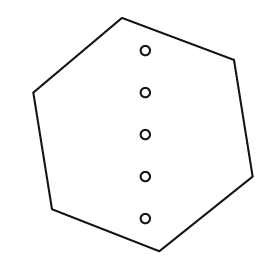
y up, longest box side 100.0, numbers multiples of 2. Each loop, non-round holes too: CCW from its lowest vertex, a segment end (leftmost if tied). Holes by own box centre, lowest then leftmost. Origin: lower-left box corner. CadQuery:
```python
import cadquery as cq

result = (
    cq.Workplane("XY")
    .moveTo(54.0, 0.0)
    .lineTo(94.0, 32.0)
    .lineTo(86.0, 82.0)
    .lineTo(38.0, 100.0)
    .lineTo(0.0, 68.0)
    .lineTo(8.0, 18.0)
    .close()
    .moveTo(48.0, 14.0)
    .circle(2.0)
    .moveTo(48.0, 32.0)
    .circle(2.0)
    .moveTo(48.0, 50.0)
    .circle(2.0)
    .moveTo(48.0, 68.0)
    .circle(2.0)
    .moveTo(48.0, 86.0)
    .circle(2.0)
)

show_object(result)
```